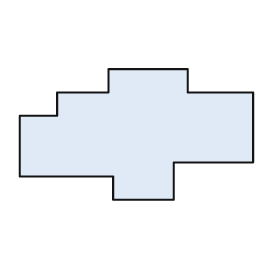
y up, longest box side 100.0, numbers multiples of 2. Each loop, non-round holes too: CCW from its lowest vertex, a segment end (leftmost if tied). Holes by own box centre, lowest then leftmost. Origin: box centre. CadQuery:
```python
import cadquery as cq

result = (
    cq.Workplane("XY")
    .moveTo(-10.0, -28.0)
    .lineTo(16.0, -28.0)
    .lineTo(16.0, -12.0)
    .lineTo(50.0, -12.0)
    .lineTo(50.0, 18.0)
    .lineTo(22.0, 18.0)
    .lineTo(22.0, 28.0)
    .lineTo(-12.0, 28.0)
    .lineTo(-12.0, 18.0)
    .lineTo(-34.0, 18.0)
    .lineTo(-34.0, 8.0)
    .lineTo(-50.0, 8.0)
    .lineTo(-50.0, -18.0)
    .lineTo(-10.0, -18.0)
    .close()
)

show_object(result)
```